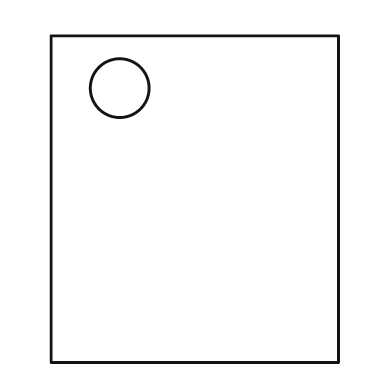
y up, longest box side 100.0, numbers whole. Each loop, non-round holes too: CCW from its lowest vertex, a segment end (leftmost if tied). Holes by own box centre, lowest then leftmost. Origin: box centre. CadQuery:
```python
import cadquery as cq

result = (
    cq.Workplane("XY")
    .moveTo(-44.0, -50.0)
    .lineTo(44.0, -50.0)
    .lineTo(44.0, 50.0)
    .lineTo(-44.0, 50.0)
    .close()
    .moveTo(-23.0, 34.0)
    .circle(9.0)
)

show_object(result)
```